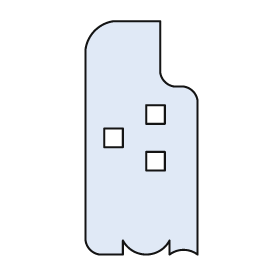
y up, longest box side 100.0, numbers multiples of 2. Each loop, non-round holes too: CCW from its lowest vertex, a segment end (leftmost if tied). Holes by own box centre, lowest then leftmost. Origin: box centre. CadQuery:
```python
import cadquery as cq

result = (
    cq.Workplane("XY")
    .moveTo(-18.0, -50.0)
    .lineTo(-8.0, -50.0)
    .lineTo(-8.0, -44.0)
    .threePointArc((2.0, -50.0), (12.0, -44.0))
    .lineTo(12.0, -50.0)
    .threePointArc((18.0, -48.0), (24.0, -50.0))
    .lineTo(24.0, 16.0)
    .threePointArc((22.0, 20.0), (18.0, 22.0))
    .lineTo(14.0, 22.0)
    .threePointArc((10.0, 24.0), (8.0, 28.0))
    .lineTo(8.0, 50.0)
    .lineTo(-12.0, 50.0)
    .threePointArc((-20.0, 46.0), (-24.0, 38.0))
    .lineTo(-24.0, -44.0)
    .threePointArc((-22.0, -48.0), (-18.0, -50.0))
    .close()
    .moveTo(2.0, -14.0)
    .lineTo(10.0, -14.0)
    .lineTo(10.0, -6.0)
    .lineTo(2.0, -6.0)
    .close()
    .moveTo(-16.0, -4.0)
    .lineTo(-8.0, -4.0)
    .lineTo(-8.0, 4.0)
    .lineTo(-16.0, 4.0)
    .close()
    .moveTo(2.0, 6.0)
    .lineTo(10.0, 6.0)
    .lineTo(10.0, 14.0)
    .lineTo(2.0, 14.0)
    .close()
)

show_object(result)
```